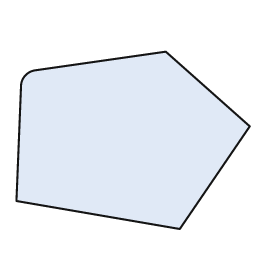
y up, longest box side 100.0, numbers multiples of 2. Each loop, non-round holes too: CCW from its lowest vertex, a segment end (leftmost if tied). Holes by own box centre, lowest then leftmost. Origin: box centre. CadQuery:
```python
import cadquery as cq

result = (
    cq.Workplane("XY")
    .moveTo(20.0, -38.0)
    .lineTo(50.0, 6.0)
    .lineTo(14.0, 38.0)
    .lineTo(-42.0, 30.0)
    .threePointArc((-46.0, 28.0), (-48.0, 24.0))
    .lineTo(-50.0, -26.0)
    .close()
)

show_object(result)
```